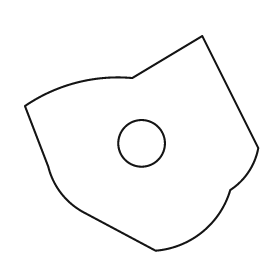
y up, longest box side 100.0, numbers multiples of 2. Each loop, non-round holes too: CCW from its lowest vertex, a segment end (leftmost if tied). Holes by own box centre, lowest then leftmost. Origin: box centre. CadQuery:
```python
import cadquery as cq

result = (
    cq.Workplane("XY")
    .moveTo(6.0, -46.0)
    .threePointArc((26.0, -38.0), (38.0, -20.0))
    .threePointArc((46.0, -12.0), (50.0, -2.0))
    .lineTo(26.0, 46.0)
    .lineTo(-4.0, 28.0)
    .threePointArc((-28.0, 26.0), (-50.0, 16.0))
    .lineTo(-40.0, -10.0)
    .threePointArc((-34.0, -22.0), (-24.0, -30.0))
    .close()
    .moveTo(0.0, 0.0)
    .circle(10.0)
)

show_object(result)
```